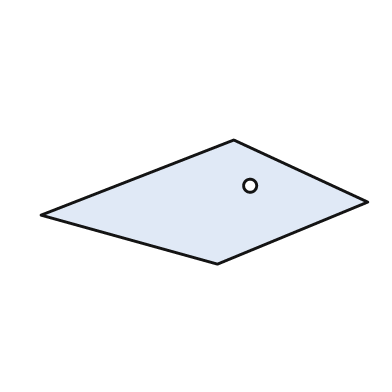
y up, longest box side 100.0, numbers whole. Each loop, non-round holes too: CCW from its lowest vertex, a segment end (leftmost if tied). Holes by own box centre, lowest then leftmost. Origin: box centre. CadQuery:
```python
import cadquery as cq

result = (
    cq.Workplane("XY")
    .moveTo(4.0, -19.0)
    .lineTo(50.0, 0.0)
    .lineTo(9.0, 19.0)
    .lineTo(-50.0, -4.0)
    .close()
    .moveTo(14.0, 5.0)
    .circle(2.0)
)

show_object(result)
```